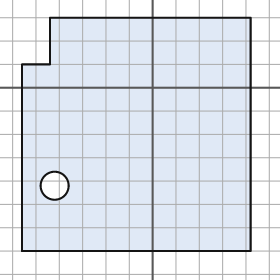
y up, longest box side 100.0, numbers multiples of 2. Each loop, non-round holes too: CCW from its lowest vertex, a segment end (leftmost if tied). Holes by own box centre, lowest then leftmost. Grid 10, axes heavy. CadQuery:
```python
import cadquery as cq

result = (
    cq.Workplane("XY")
    .moveTo(-56.0, -70.0)
    .lineTo(42.0, -70.0)
    .lineTo(42.0, 30.0)
    .lineTo(-44.0, 30.0)
    .lineTo(-44.0, 10.0)
    .lineTo(-56.0, 10.0)
    .close()
    .moveTo(-42.0, -42.0)
    .circle(6.0)
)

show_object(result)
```